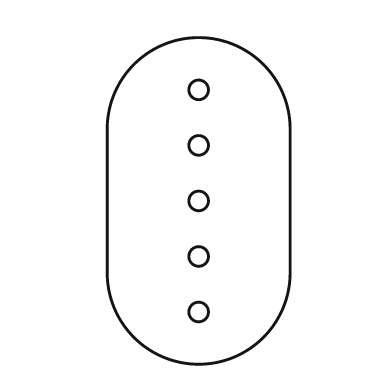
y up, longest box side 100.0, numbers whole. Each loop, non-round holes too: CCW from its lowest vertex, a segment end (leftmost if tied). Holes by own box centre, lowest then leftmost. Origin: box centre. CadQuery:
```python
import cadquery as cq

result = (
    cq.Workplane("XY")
    .moveTo(-28.0, -22.0)
    .threePointArc((0.0, -50.0), (28.0, -22.0))
    .lineTo(28.0, 22.0)
    .threePointArc((0.0, 50.0), (-28.0, 22.0))
    .close()
    .moveTo(0.0, -34.0)
    .circle(3.0)
    .moveTo(0.0, -17.0)
    .circle(3.0)
    .moveTo(0.0, 0.0)
    .circle(3.0)
    .moveTo(0.0, 17.0)
    .circle(3.0)
    .moveTo(0.0, 34.0)
    .circle(3.0)
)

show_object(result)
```